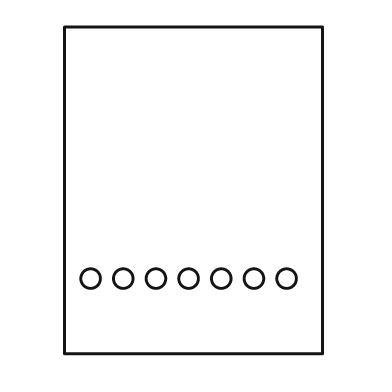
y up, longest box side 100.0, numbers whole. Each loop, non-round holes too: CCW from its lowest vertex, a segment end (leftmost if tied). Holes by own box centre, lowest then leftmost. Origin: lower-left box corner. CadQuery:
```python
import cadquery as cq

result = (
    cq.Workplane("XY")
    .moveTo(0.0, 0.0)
    .lineTo(79.0, 0.0)
    .lineTo(79.0, 100.0)
    .lineTo(0.0, 100.0)
    .close()
    .moveTo(8.0, 23.0)
    .circle(3.0)
    .moveTo(18.0, 23.0)
    .circle(3.0)
    .moveTo(28.0, 23.0)
    .circle(3.0)
    .moveTo(38.0, 23.0)
    .circle(3.0)
    .moveTo(48.0, 23.0)
    .circle(3.0)
    .moveTo(58.0, 23.0)
    .circle(3.0)
    .moveTo(68.0, 23.0)
    .circle(3.0)
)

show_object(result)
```